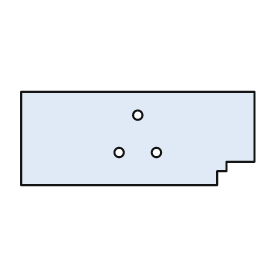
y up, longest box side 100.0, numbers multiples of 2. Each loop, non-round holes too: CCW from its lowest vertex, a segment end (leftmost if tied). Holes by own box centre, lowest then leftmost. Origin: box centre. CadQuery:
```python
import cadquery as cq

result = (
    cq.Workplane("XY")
    .moveTo(-50.0, -20.0)
    .lineTo(34.0, -20.0)
    .lineTo(34.0, -14.0)
    .lineTo(38.0, -14.0)
    .lineTo(38.0, -10.0)
    .lineTo(50.0, -10.0)
    .lineTo(50.0, 20.0)
    .lineTo(-50.0, 20.0)
    .close()
    .moveTo(-8.0, -6.0)
    .circle(2.0)
    .moveTo(8.0, -6.0)
    .circle(2.0)
    .moveTo(0.0, 10.0)
    .circle(2.0)
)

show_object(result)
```